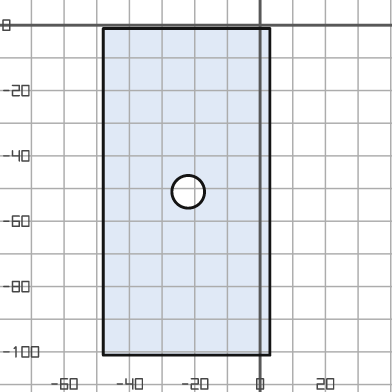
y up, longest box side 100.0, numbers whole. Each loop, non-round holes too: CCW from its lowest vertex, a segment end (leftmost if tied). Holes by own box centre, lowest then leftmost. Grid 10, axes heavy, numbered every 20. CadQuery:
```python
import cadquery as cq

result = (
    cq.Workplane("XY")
    .moveTo(-48.0, -101.0)
    .lineTo(3.0, -101.0)
    .lineTo(3.0, -1.0)
    .lineTo(-48.0, -1.0)
    .close()
    .moveTo(-22.0, -51.0)
    .circle(5.0)
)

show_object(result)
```